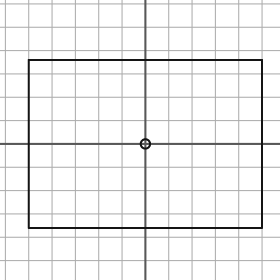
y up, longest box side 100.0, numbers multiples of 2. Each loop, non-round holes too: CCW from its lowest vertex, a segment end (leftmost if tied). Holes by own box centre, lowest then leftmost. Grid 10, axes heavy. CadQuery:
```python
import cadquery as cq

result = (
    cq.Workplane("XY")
    .moveTo(-50.0, -36.0)
    .lineTo(50.0, -36.0)
    .lineTo(50.0, 36.0)
    .lineTo(-50.0, 36.0)
    .close()
    .moveTo(0.0, 0.0)
    .circle(2.0)
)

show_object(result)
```